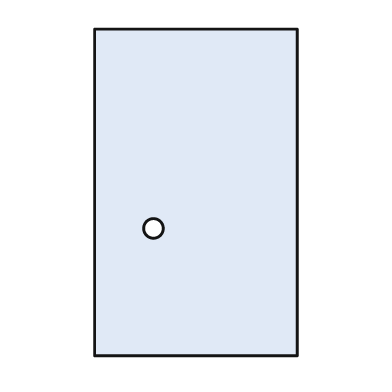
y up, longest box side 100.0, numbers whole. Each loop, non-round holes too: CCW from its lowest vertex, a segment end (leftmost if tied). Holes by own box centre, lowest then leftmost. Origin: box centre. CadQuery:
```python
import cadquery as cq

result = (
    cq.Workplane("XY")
    .moveTo(-31.0, -50.0)
    .lineTo(31.0, -50.0)
    .lineTo(31.0, 50.0)
    .lineTo(-31.0, 50.0)
    .close()
    .moveTo(-13.0, -11.0)
    .circle(3.0)
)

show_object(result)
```